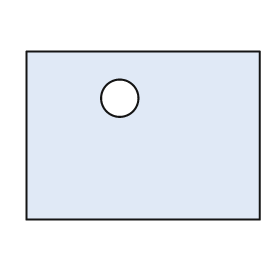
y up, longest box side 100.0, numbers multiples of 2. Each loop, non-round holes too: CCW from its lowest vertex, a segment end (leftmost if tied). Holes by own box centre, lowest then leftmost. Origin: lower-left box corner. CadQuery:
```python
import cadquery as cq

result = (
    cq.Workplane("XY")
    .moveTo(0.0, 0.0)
    .lineTo(100.0, 0.0)
    .lineTo(100.0, 72.0)
    .lineTo(0.0, 72.0)
    .close()
    .moveTo(40.0, 52.0)
    .circle(8.0)
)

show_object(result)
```